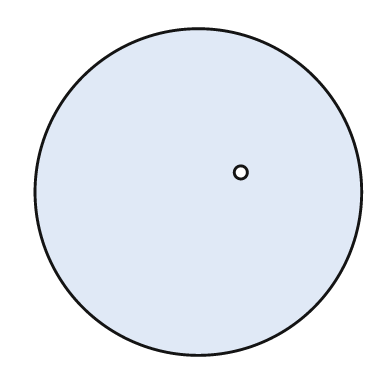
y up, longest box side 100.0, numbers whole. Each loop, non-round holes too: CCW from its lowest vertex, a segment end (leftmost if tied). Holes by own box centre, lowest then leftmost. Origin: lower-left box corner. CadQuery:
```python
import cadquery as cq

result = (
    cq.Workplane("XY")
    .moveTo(50.0, 50.0)
    .circle(50.0)
    .moveTo(63.0, 56.0)
    .circle(2.0)
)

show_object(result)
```